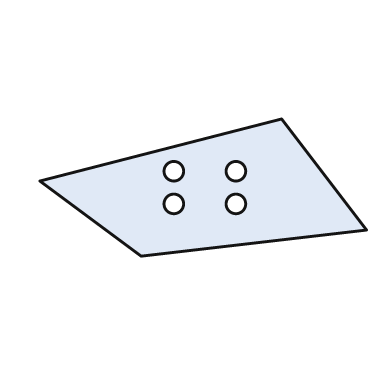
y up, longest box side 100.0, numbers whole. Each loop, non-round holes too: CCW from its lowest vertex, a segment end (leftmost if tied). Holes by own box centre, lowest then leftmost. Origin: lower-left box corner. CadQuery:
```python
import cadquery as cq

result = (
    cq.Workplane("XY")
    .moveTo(31.0, 0.0)
    .lineTo(100.0, 8.0)
    .lineTo(74.0, 42.0)
    .lineTo(0.0, 23.0)
    .close()
    .moveTo(41.0, 16.0)
    .circle(3.0)
    .moveTo(60.0, 16.0)
    .circle(3.0)
    .moveTo(41.0, 26.0)
    .circle(3.0)
    .moveTo(60.0, 26.0)
    .circle(3.0)
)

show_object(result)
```